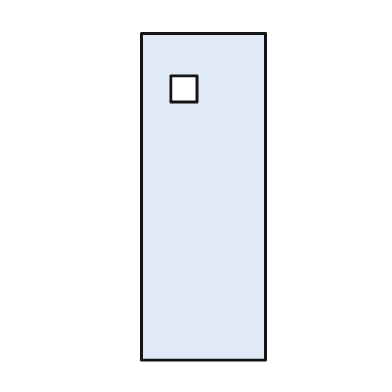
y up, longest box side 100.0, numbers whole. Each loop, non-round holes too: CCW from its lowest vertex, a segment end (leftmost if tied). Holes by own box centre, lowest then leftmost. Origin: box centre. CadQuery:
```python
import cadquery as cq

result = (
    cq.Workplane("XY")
    .moveTo(-19.0, -50.0)
    .lineTo(19.0, -50.0)
    .lineTo(19.0, 50.0)
    .lineTo(-19.0, 50.0)
    .close()
    .moveTo(-10.0, 29.0)
    .lineTo(-2.0, 29.0)
    .lineTo(-2.0, 37.0)
    .lineTo(-10.0, 37.0)
    .close()
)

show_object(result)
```